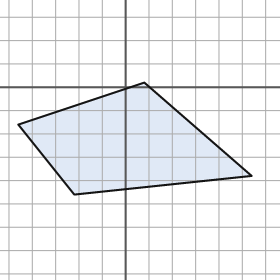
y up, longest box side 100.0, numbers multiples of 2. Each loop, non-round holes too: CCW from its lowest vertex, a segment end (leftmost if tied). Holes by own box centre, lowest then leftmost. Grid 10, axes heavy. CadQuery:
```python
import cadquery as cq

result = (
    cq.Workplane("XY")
    .moveTo(-22.0, -46.0)
    .lineTo(54.0, -38.0)
    .lineTo(8.0, 2.0)
    .lineTo(-46.0, -16.0)
    .close()
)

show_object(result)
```